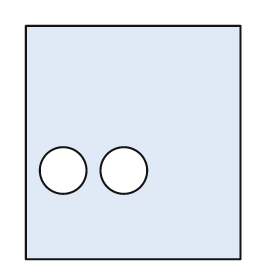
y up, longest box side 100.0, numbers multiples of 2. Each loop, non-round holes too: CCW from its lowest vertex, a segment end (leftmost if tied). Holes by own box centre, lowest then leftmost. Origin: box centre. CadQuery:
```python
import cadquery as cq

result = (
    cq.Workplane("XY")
    .moveTo(-46.0, -50.0)
    .lineTo(46.0, -50.0)
    .lineTo(46.0, 50.0)
    .lineTo(-46.0, 50.0)
    .close()
    .moveTo(-30.0, -12.0)
    .circle(10.0)
    .moveTo(-4.0, -12.0)
    .circle(10.0)
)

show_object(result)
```